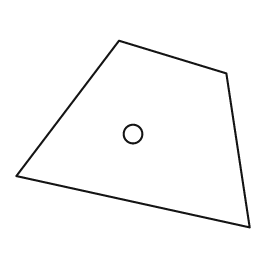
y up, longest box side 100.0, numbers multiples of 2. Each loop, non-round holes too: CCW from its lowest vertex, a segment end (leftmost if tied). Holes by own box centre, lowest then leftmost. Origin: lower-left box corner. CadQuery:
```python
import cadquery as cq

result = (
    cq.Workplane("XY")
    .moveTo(100.0, 0.0)
    .lineTo(90.0, 66.0)
    .lineTo(44.0, 80.0)
    .lineTo(0.0, 22.0)
    .close()
    .moveTo(50.0, 40.0)
    .circle(4.0)
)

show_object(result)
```